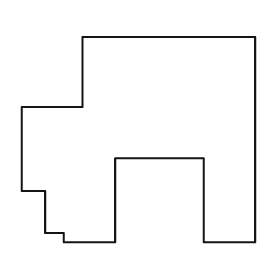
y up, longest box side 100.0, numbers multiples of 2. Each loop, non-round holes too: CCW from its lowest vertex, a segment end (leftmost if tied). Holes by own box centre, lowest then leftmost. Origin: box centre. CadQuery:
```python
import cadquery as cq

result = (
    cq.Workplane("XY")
    .moveTo(-32.0, -44.0)
    .lineTo(-10.0, -44.0)
    .lineTo(-10.0, -8.0)
    .lineTo(28.0, -8.0)
    .lineTo(28.0, -44.0)
    .lineTo(50.0, -44.0)
    .lineTo(50.0, 44.0)
    .lineTo(-24.0, 44.0)
    .lineTo(-24.0, 14.0)
    .lineTo(-50.0, 14.0)
    .lineTo(-50.0, -22.0)
    .lineTo(-40.0, -22.0)
    .lineTo(-40.0, -40.0)
    .lineTo(-32.0, -40.0)
    .close()
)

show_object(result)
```